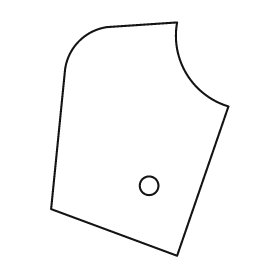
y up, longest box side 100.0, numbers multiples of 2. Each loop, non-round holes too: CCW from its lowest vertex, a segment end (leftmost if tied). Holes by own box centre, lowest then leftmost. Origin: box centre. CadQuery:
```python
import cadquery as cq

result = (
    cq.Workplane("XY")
    .moveTo(16.0, -50.0)
    .lineTo(38.0, 14.0)
    .threePointArc((20.0, 28.0), (16.0, 50.0))
    .lineTo(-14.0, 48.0)
    .threePointArc((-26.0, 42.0), (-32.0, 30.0))
    .lineTo(-38.0, -30.0)
    .close()
    .moveTo(4.0, -20.0)
    .circle(4.0)
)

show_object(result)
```